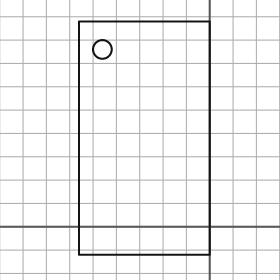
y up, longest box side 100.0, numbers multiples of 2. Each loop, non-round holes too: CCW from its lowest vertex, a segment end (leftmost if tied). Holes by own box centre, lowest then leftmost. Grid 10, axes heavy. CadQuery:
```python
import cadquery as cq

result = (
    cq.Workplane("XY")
    .moveTo(-56.0, -12.0)
    .lineTo(0.0, -12.0)
    .lineTo(0.0, 88.0)
    .lineTo(-56.0, 88.0)
    .close()
    .moveTo(-46.0, 76.0)
    .circle(4.0)
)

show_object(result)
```